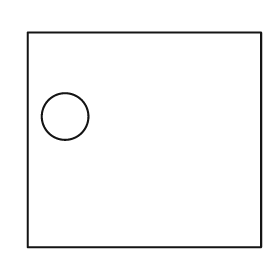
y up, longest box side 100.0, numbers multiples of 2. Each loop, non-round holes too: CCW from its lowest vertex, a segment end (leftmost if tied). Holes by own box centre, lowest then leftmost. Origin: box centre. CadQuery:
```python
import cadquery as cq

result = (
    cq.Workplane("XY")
    .moveTo(-50.0, -46.0)
    .lineTo(50.0, -46.0)
    .lineTo(50.0, 46.0)
    .lineTo(-50.0, 46.0)
    .close()
    .moveTo(-34.0, 10.0)
    .circle(10.0)
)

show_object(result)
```